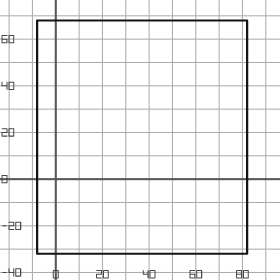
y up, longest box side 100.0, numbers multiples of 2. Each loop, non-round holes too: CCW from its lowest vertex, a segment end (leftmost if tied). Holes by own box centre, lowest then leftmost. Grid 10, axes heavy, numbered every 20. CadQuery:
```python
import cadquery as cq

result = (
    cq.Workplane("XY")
    .moveTo(-8.0, -32.0)
    .lineTo(82.0, -32.0)
    .lineTo(82.0, 68.0)
    .lineTo(-8.0, 68.0)
    .close()
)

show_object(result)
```